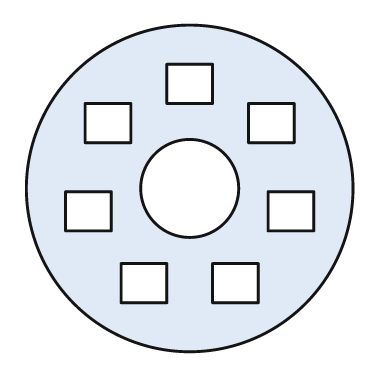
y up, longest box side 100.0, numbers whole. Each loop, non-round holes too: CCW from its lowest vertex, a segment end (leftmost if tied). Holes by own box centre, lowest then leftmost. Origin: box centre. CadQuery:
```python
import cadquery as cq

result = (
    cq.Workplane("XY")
    .moveTo(0.0, 0.0)
    .circle(50.0)
    .moveTo(-21.0, -35.0)
    .lineTo(-7.0, -35.0)
    .lineTo(-7.0, -23.0)
    .lineTo(-21.0, -23.0)
    .close()
    .moveTo(7.0, -35.0)
    .lineTo(21.0, -35.0)
    .lineTo(21.0, -23.0)
    .lineTo(7.0, -23.0)
    .close()
    .moveTo(-38.0, -13.0)
    .lineTo(-24.0, -13.0)
    .lineTo(-24.0, -1.0)
    .lineTo(-38.0, -1.0)
    .close()
    .moveTo(24.0, -13.0)
    .lineTo(38.0, -13.0)
    .lineTo(38.0, -1.0)
    .lineTo(24.0, -1.0)
    .close()
    .moveTo(0.0, 0.0)
    .circle(15.0)
    .moveTo(-32.0, 14.0)
    .lineTo(-18.0, 14.0)
    .lineTo(-18.0, 26.0)
    .lineTo(-32.0, 26.0)
    .close()
    .moveTo(18.0, 14.0)
    .lineTo(32.0, 14.0)
    .lineTo(32.0, 26.0)
    .lineTo(18.0, 26.0)
    .close()
    .moveTo(-7.0, 26.0)
    .lineTo(7.0, 26.0)
    .lineTo(7.0, 38.0)
    .lineTo(-7.0, 38.0)
    .close()
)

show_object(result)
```